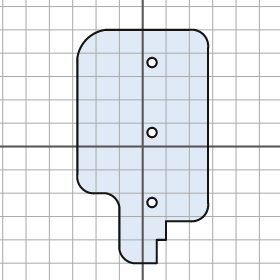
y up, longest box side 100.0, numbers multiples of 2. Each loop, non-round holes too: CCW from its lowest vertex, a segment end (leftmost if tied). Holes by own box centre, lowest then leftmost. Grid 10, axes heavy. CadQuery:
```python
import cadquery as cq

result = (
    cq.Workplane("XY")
    .moveTo(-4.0, -50.0)
    .lineTo(6.0, -50.0)
    .lineTo(6.0, -40.0)
    .lineTo(10.0, -40.0)
    .lineTo(10.0, -32.0)
    .lineTo(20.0, -32.0)
    .threePointArc((26.0, -30.0), (28.0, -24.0))
    .lineTo(28.0, 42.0)
    .threePointArc((26.0, 48.0), (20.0, 50.0))
    .lineTo(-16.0, 50.0)
    .threePointArc((-24.0, 46.0), (-28.0, 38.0))
    .lineTo(-28.0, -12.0)
    .threePointArc((-26.0, -18.0), (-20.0, -20.0))
    .lineTo(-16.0, -20.0)
    .threePointArc((-12.0, -22.0), (-10.0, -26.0))
    .lineTo(-10.0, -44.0)
    .threePointArc((-8.0, -48.0), (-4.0, -50.0))
    .close()
    .moveTo(4.0, -24.0)
    .circle(2.0)
    .moveTo(4.0, 6.0)
    .circle(2.0)
    .moveTo(4.0, 36.0)
    .circle(2.0)
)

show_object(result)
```